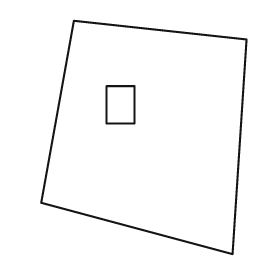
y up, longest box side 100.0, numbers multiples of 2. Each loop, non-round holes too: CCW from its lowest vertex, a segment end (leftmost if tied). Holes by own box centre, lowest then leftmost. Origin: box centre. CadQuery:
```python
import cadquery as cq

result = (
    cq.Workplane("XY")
    .moveTo(38.0, -50.0)
    .lineTo(44.0, 42.0)
    .lineTo(-30.0, 50.0)
    .lineTo(-44.0, -28.0)
    .close()
    .moveTo(-16.0, 6.0)
    .lineTo(-4.0, 6.0)
    .lineTo(-4.0, 22.0)
    .lineTo(-16.0, 22.0)
    .close()
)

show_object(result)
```